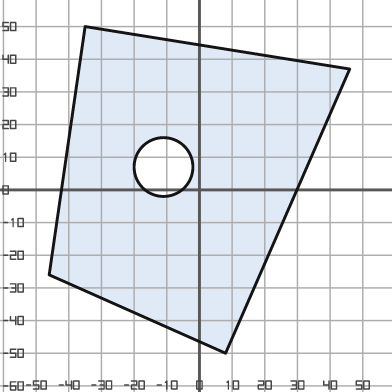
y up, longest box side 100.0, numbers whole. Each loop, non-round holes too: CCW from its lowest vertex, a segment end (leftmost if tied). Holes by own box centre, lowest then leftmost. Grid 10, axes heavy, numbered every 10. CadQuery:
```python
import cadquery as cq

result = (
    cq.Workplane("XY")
    .moveTo(8.0, -50.0)
    .lineTo(46.0, 37.0)
    .lineTo(-35.0, 50.0)
    .lineTo(-46.0, -26.0)
    .close()
    .moveTo(-11.0, 7.0)
    .circle(9.0)
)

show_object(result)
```